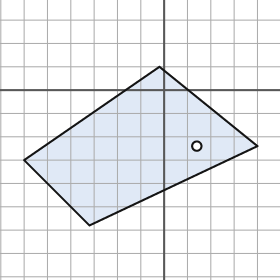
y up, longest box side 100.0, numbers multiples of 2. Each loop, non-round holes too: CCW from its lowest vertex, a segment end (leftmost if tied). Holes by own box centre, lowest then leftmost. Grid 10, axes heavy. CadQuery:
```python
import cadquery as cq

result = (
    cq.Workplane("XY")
    .moveTo(-32.0, -58.0)
    .lineTo(40.0, -24.0)
    .lineTo(-2.0, 10.0)
    .lineTo(-60.0, -30.0)
    .close()
    .moveTo(14.0, -24.0)
    .circle(2.0)
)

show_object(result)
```